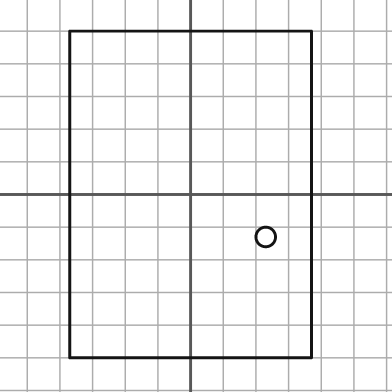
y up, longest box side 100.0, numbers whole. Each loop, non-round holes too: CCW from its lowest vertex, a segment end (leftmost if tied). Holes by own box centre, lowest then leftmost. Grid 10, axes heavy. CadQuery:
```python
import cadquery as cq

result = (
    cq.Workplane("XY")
    .moveTo(-37.0, -50.0)
    .lineTo(37.0, -50.0)
    .lineTo(37.0, 50.0)
    .lineTo(-37.0, 50.0)
    .close()
    .moveTo(23.0, -13.0)
    .circle(3.0)
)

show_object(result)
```